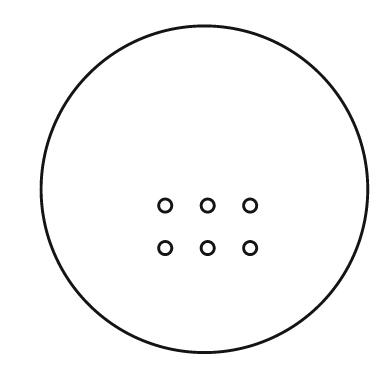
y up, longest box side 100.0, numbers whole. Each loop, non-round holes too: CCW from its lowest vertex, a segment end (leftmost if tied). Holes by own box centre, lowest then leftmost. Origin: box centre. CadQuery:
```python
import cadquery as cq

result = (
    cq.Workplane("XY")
    .moveTo(0.0, 0.0)
    .circle(50.0)
    .moveTo(-12.0, -18.0)
    .circle(2.0)
    .moveTo(1.0, -18.0)
    .circle(2.0)
    .moveTo(14.0, -18.0)
    .circle(2.0)
    .moveTo(-12.0, -5.0)
    .circle(2.0)
    .moveTo(1.0, -5.0)
    .circle(2.0)
    .moveTo(14.0, -5.0)
    .circle(2.0)
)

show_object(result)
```